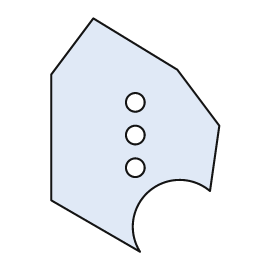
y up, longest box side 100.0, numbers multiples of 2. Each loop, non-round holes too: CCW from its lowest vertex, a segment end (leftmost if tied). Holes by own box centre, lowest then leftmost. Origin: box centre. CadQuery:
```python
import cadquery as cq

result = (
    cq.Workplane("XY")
    .moveTo(2.0, -50.0)
    .threePointArc((6.0, -24.0), (32.0, -24.0))
    .lineTo(36.0, 4.0)
    .lineTo(18.0, 28.0)
    .lineTo(-18.0, 50.0)
    .lineTo(-36.0, 26.0)
    .lineTo(-36.0, -28.0)
    .close()
    .moveTo(0.0, -14.0)
    .circle(4.0)
    .moveTo(0.0, 0.0)
    .circle(4.0)
    .moveTo(0.0, 14.0)
    .circle(4.0)
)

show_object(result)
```